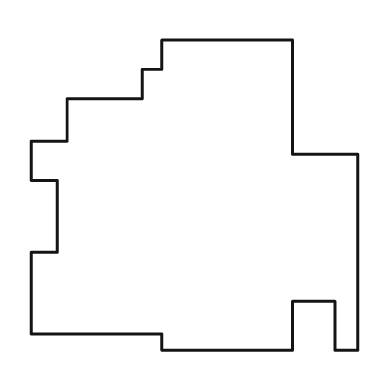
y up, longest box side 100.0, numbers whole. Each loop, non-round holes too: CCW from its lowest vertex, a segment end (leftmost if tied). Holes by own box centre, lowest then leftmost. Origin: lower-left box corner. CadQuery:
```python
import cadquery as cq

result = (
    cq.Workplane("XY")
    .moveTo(40.0, 0.0)
    .lineTo(80.0, 0.0)
    .lineTo(80.0, 15.0)
    .lineTo(93.0, 15.0)
    .lineTo(93.0, 0.0)
    .lineTo(100.0, 0.0)
    .lineTo(100.0, 60.0)
    .lineTo(80.0, 60.0)
    .lineTo(80.0, 95.0)
    .lineTo(40.0, 95.0)
    .lineTo(40.0, 86.0)
    .lineTo(34.0, 86.0)
    .lineTo(34.0, 77.0)
    .lineTo(11.0, 77.0)
    .lineTo(11.0, 64.0)
    .lineTo(0.0, 64.0)
    .lineTo(0.0, 52.0)
    .lineTo(8.0, 52.0)
    .lineTo(8.0, 30.0)
    .lineTo(0.0, 30.0)
    .lineTo(0.0, 5.0)
    .lineTo(40.0, 5.0)
    .close()
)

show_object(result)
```